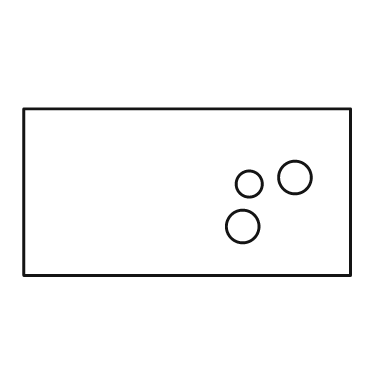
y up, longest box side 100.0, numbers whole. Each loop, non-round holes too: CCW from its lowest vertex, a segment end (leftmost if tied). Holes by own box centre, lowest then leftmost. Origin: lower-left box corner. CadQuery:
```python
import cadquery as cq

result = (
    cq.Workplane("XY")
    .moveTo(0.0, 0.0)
    .lineTo(100.0, 0.0)
    .lineTo(100.0, 51.0)
    .lineTo(0.0, 51.0)
    .close()
    .moveTo(67.0, 15.0)
    .circle(5.0)
    .moveTo(69.0, 28.0)
    .circle(4.0)
    .moveTo(83.0, 30.0)
    .circle(5.0)
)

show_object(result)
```